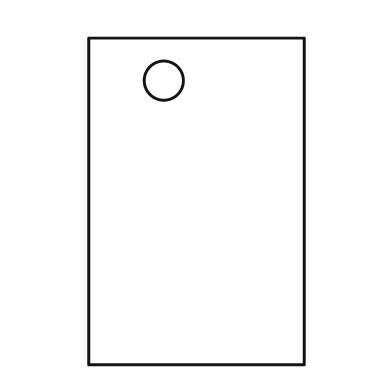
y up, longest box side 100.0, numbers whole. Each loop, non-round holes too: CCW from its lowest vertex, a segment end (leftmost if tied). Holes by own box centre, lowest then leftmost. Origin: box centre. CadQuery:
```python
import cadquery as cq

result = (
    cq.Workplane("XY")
    .moveTo(-33.0, -50.0)
    .lineTo(33.0, -50.0)
    .lineTo(33.0, 50.0)
    .lineTo(-33.0, 50.0)
    .close()
    .moveTo(-10.0, 37.0)
    .circle(6.0)
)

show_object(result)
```